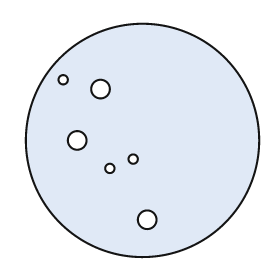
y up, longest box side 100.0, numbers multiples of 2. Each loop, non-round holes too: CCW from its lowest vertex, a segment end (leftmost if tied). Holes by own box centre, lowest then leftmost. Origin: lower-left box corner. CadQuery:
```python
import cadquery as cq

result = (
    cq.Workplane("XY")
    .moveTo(50.0, 50.0)
    .circle(50.0)
    .moveTo(52.0, 16.0)
    .circle(4.0)
    .moveTo(36.0, 38.0)
    .circle(2.0)
    .moveTo(46.0, 42.0)
    .circle(2.0)
    .moveTo(22.0, 50.0)
    .circle(4.0)
    .moveTo(32.0, 72.0)
    .circle(4.0)
    .moveTo(16.0, 76.0)
    .circle(2.0)
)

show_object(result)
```